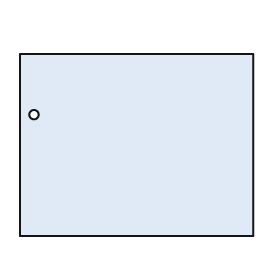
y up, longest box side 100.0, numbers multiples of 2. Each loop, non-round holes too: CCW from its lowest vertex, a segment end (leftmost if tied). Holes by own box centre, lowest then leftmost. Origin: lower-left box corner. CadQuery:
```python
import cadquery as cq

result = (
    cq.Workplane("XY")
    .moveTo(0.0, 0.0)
    .lineTo(100.0, 0.0)
    .lineTo(100.0, 78.0)
    .lineTo(0.0, 78.0)
    .close()
    .moveTo(6.0, 52.0)
    .circle(2.0)
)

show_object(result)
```